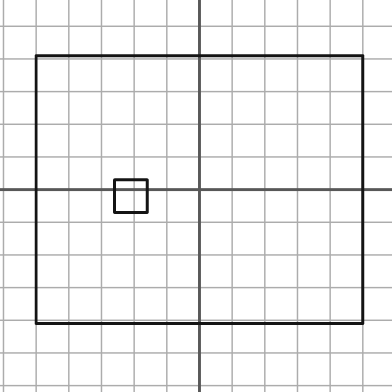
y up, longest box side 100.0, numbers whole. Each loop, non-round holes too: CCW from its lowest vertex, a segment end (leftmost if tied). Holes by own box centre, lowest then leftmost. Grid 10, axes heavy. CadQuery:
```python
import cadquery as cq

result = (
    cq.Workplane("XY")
    .moveTo(-50.0, -41.0)
    .lineTo(50.0, -41.0)
    .lineTo(50.0, 41.0)
    .lineTo(-50.0, 41.0)
    .close()
    .moveTo(-26.0, -7.0)
    .lineTo(-16.0, -7.0)
    .lineTo(-16.0, 3.0)
    .lineTo(-26.0, 3.0)
    .close()
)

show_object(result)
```